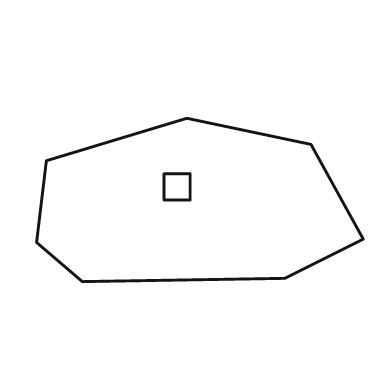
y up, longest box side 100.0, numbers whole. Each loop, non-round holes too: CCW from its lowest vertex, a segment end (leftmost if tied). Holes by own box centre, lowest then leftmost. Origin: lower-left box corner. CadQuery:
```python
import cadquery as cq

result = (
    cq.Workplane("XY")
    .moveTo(14.0, 0.0)
    .lineTo(76.0, 1.0)
    .lineTo(100.0, 13.0)
    .lineTo(84.0, 42.0)
    .lineTo(46.0, 50.0)
    .lineTo(3.0, 37.0)
    .lineTo(0.0, 12.0)
    .close()
    .moveTo(39.0, 25.0)
    .lineTo(47.0, 25.0)
    .lineTo(47.0, 33.0)
    .lineTo(39.0, 33.0)
    .close()
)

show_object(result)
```